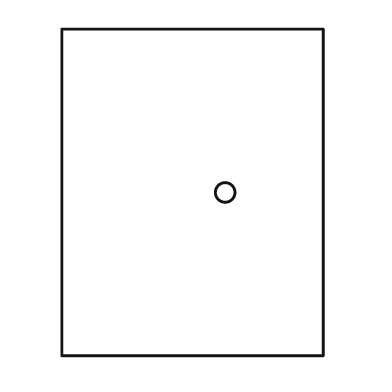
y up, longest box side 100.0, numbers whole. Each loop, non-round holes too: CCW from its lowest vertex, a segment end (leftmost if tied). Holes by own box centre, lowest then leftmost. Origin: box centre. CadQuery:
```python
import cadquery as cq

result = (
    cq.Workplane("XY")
    .moveTo(-40.0, -50.0)
    .lineTo(40.0, -50.0)
    .lineTo(40.0, 50.0)
    .lineTo(-40.0, 50.0)
    .close()
    .moveTo(10.0, 0.0)
    .circle(3.0)
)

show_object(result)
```